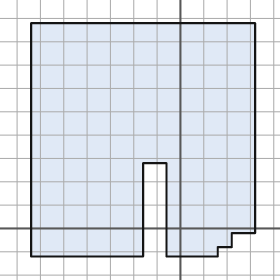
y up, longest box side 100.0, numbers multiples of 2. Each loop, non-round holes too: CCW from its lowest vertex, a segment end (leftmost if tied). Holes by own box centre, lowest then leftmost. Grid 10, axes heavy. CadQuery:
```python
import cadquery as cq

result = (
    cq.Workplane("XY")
    .moveTo(-64.0, -12.0)
    .lineTo(-16.0, -12.0)
    .lineTo(-16.0, 28.0)
    .lineTo(-6.0, 28.0)
    .lineTo(-6.0, -12.0)
    .lineTo(16.0, -12.0)
    .lineTo(16.0, -8.0)
    .lineTo(22.0, -8.0)
    .lineTo(22.0, -2.0)
    .lineTo(32.0, -2.0)
    .lineTo(32.0, 88.0)
    .lineTo(-64.0, 88.0)
    .close()
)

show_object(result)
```